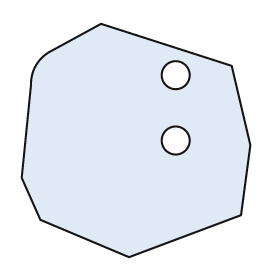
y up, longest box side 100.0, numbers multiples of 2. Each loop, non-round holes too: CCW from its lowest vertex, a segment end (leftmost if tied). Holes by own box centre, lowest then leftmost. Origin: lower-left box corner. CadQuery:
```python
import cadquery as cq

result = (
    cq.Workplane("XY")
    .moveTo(46.0, 0.0)
    .lineTo(94.0, 18.0)
    .lineTo(98.0, 48.0)
    .lineTo(90.0, 82.0)
    .lineTo(34.0, 100.0)
    .lineTo(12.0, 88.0)
    .threePointArc((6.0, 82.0), (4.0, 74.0))
    .lineTo(0.0, 34.0)
    .lineTo(8.0, 16.0)
    .close()
    .moveTo(66.0, 50.0)
    .circle(6.0)
    .moveTo(66.0, 78.0)
    .circle(6.0)
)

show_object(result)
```